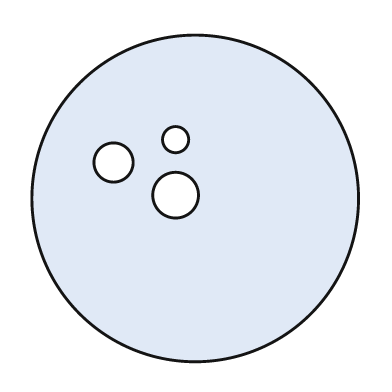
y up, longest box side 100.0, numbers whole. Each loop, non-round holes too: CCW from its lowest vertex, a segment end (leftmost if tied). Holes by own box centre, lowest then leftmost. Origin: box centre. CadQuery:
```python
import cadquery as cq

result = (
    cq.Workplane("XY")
    .moveTo(0.0, 0.0)
    .circle(50.0)
    .moveTo(-6.0, 1.0)
    .circle(7.0)
    .moveTo(-25.0, 11.0)
    .circle(6.0)
    .moveTo(-6.0, 18.0)
    .circle(4.0)
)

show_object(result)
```